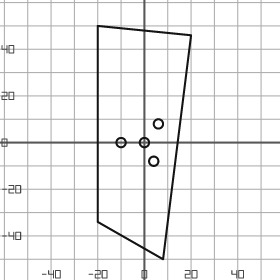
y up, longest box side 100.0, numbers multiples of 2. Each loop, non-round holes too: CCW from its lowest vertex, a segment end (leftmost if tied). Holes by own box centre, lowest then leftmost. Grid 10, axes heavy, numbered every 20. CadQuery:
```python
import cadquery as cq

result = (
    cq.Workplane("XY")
    .moveTo(8.0, -50.0)
    .lineTo(20.0, 46.0)
    .lineTo(-20.0, 50.0)
    .lineTo(-20.0, -34.0)
    .close()
    .moveTo(4.0, -8.0)
    .circle(2.0)
    .moveTo(-10.0, 0.0)
    .circle(2.0)
    .moveTo(0.0, 0.0)
    .circle(2.0)
    .moveTo(6.0, 8.0)
    .circle(2.0)
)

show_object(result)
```